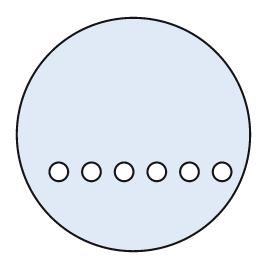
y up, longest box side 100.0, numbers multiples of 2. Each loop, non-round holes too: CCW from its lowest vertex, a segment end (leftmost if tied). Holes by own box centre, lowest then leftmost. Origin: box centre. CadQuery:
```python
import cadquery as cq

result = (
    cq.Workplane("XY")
    .moveTo(0.0, 0.0)
    .circle(50.0)
    .moveTo(-32.0, -16.0)
    .circle(4.0)
    .moveTo(-18.0, -16.0)
    .circle(4.0)
    .moveTo(-4.0, -16.0)
    .circle(4.0)
    .moveTo(10.0, -16.0)
    .circle(4.0)
    .moveTo(24.0, -16.0)
    .circle(4.0)
    .moveTo(38.0, -16.0)
    .circle(4.0)
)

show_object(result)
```